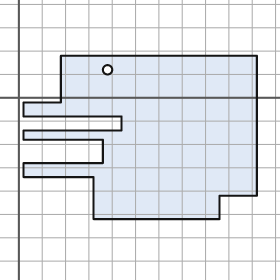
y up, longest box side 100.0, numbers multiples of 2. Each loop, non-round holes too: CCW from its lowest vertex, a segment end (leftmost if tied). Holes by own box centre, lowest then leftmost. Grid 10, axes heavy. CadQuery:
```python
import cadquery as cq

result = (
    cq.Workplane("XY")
    .moveTo(32.0, -52.0)
    .lineTo(86.0, -52.0)
    .lineTo(86.0, -42.0)
    .lineTo(102.0, -42.0)
    .lineTo(102.0, 18.0)
    .lineTo(18.0, 18.0)
    .lineTo(18.0, -2.0)
    .lineTo(2.0, -2.0)
    .lineTo(2.0, -8.0)
    .lineTo(44.0, -8.0)
    .lineTo(44.0, -14.0)
    .lineTo(2.0, -14.0)
    .lineTo(2.0, -18.0)
    .lineTo(36.0, -18.0)
    .lineTo(36.0, -28.0)
    .lineTo(2.0, -28.0)
    .lineTo(2.0, -34.0)
    .lineTo(32.0, -34.0)
    .close()
    .moveTo(38.0, 12.0)
    .circle(2.0)
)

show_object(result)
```